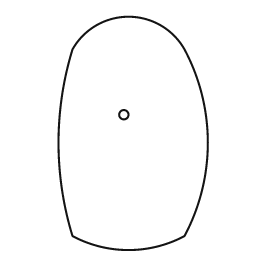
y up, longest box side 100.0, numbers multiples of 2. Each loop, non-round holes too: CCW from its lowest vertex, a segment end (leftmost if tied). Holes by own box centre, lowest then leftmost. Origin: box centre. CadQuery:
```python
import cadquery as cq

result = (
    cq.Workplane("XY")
    .moveTo(-26.0, -44.0)
    .threePointArc((-2.0, -50.0), (22.0, -44.0))
    .threePointArc((32.0, -4.0), (22.0, 36.0))
    .threePointArc((-2.0, 50.0), (-26.0, 36.0))
    .threePointArc((-32.0, -4.0), (-26.0, -44.0))
    .close()
    .moveTo(-4.0, 8.0)
    .circle(2.0)
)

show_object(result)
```